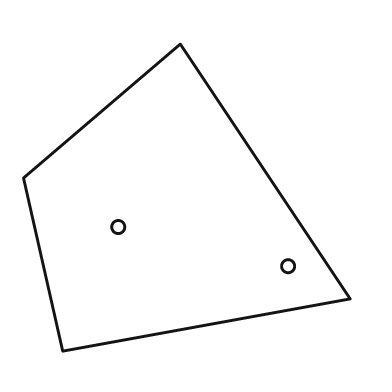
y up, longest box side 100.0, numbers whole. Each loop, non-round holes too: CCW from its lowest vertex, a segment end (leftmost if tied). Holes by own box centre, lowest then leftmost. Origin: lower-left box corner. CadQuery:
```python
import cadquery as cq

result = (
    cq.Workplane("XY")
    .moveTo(12.0, 0.0)
    .lineTo(100.0, 16.0)
    .lineTo(48.0, 94.0)
    .lineTo(0.0, 53.0)
    .close()
    .moveTo(81.0, 26.0)
    .circle(2.0)
    .moveTo(29.0, 38.0)
    .circle(2.0)
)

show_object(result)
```